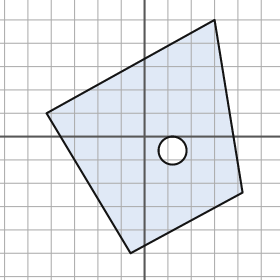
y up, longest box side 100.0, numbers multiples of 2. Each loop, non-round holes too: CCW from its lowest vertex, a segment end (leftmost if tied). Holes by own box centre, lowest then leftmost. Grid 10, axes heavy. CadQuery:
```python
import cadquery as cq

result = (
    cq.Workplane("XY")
    .moveTo(-6.0, -50.0)
    .lineTo(42.0, -24.0)
    .lineTo(30.0, 50.0)
    .lineTo(-42.0, 10.0)
    .close()
    .moveTo(12.0, -6.0)
    .circle(6.0)
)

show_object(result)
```